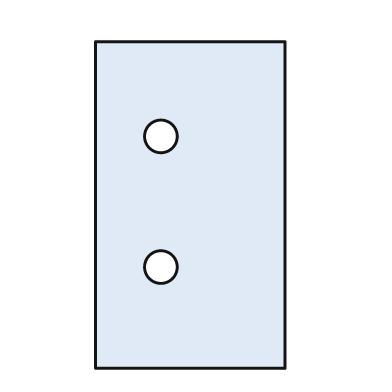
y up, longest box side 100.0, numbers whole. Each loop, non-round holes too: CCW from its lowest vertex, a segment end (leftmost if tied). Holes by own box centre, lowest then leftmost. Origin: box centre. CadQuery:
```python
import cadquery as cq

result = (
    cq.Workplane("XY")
    .moveTo(-29.0, -50.0)
    .lineTo(29.0, -50.0)
    .lineTo(29.0, 50.0)
    .lineTo(-29.0, 50.0)
    .close()
    .moveTo(-9.0, -19.0)
    .circle(5.0)
    .moveTo(-9.0, 21.0)
    .circle(5.0)
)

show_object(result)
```